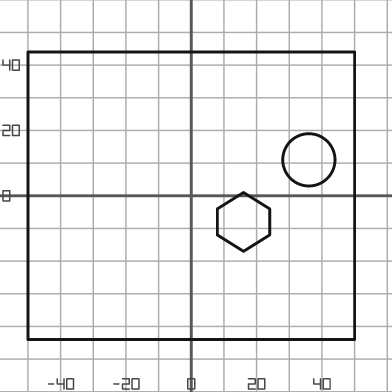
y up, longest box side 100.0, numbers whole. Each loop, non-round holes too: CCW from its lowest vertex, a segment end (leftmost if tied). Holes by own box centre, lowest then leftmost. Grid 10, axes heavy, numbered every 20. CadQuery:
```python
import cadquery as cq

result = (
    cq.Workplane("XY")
    .moveTo(-50.0, -44.0)
    .lineTo(50.0, -44.0)
    .lineTo(50.0, 44.0)
    .lineTo(-50.0, 44.0)
    .close()
    .moveTo(16.0, -17.0)
    .lineTo(24.0, -12.0)
    .lineTo(24.0, -4.0)
    .lineTo(16.0, 1.0)
    .lineTo(8.0, -4.0)
    .lineTo(8.0, -12.0)
    .close()
    .moveTo(36.0, 11.0)
    .circle(8.0)
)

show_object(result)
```